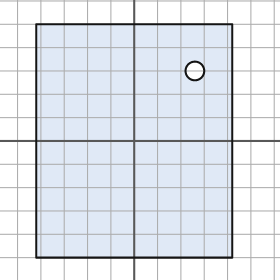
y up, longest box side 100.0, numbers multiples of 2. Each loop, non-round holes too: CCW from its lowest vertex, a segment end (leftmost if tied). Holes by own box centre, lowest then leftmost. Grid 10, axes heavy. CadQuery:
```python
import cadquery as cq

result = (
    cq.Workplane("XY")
    .moveTo(-42.0, -50.0)
    .lineTo(42.0, -50.0)
    .lineTo(42.0, 50.0)
    .lineTo(-42.0, 50.0)
    .close()
    .moveTo(26.0, 30.0)
    .circle(4.0)
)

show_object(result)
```